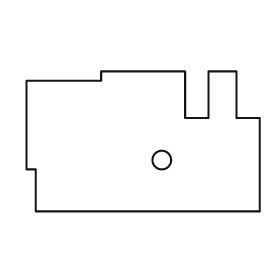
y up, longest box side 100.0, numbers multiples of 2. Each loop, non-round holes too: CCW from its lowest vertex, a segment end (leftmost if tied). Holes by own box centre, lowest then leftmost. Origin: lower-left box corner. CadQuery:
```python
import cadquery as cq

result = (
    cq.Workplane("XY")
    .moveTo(4.0, 0.0)
    .lineTo(100.0, 0.0)
    .lineTo(100.0, 40.0)
    .lineTo(90.0, 40.0)
    .lineTo(90.0, 60.0)
    .lineTo(78.0, 60.0)
    .lineTo(78.0, 40.0)
    .lineTo(68.0, 40.0)
    .lineTo(68.0, 60.0)
    .lineTo(32.0, 60.0)
    .lineTo(32.0, 56.0)
    .lineTo(0.0, 56.0)
    .lineTo(0.0, 18.0)
    .lineTo(4.0, 18.0)
    .close()
    .moveTo(58.0, 22.0)
    .circle(4.0)
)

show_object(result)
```